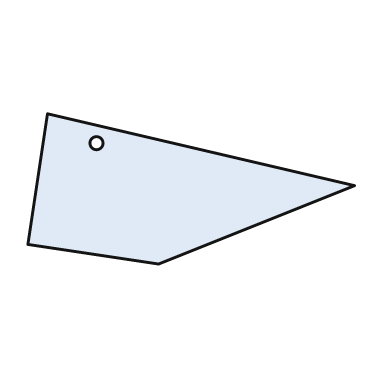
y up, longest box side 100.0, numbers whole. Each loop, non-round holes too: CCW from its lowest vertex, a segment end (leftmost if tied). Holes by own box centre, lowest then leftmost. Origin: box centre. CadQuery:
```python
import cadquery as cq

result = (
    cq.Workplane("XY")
    .moveTo(-10.0, -23.0)
    .lineTo(50.0, 1.0)
    .lineTo(-44.0, 23.0)
    .lineTo(-50.0, -17.0)
    .close()
    .moveTo(-29.0, 14.0)
    .circle(2.0)
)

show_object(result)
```